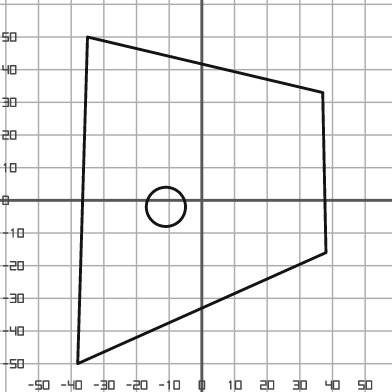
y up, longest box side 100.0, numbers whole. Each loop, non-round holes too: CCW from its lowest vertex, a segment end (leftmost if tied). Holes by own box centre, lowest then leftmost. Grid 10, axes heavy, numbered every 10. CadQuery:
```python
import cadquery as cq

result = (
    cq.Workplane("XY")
    .moveTo(-38.0, -50.0)
    .lineTo(38.0, -16.0)
    .lineTo(37.0, 33.0)
    .lineTo(-35.0, 50.0)
    .close()
    .moveTo(-11.0, -2.0)
    .circle(6.0)
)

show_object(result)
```